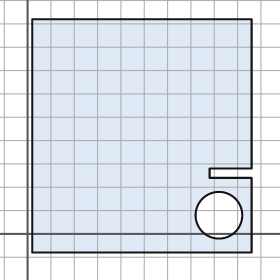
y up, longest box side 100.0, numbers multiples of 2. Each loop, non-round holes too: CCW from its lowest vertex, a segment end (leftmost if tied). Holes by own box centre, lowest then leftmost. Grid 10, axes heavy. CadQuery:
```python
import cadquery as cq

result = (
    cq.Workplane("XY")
    .moveTo(2.0, -8.0)
    .lineTo(96.0, -8.0)
    .lineTo(96.0, 24.0)
    .lineTo(78.0, 24.0)
    .lineTo(78.0, 28.0)
    .lineTo(96.0, 28.0)
    .lineTo(96.0, 92.0)
    .lineTo(2.0, 92.0)
    .close()
    .moveTo(82.0, 8.0)
    .circle(10.0)
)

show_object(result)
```